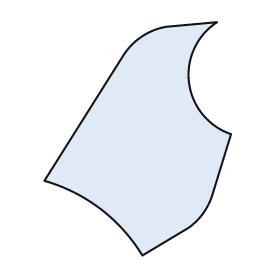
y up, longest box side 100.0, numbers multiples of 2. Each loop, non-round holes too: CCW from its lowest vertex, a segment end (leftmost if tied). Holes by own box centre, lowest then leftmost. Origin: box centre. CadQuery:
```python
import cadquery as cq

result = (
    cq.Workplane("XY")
    .moveTo(2.0, -50.0)
    .lineTo(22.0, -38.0)
    .threePointArc((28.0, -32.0), (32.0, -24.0))
    .lineTo(40.0, 2.0)
    .threePointArc((22.0, 24.0), (34.0, 50.0))
    .lineTo(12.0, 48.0)
    .threePointArc((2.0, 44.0), (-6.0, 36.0))
    .lineTo(-40.0, -18.0)
    .threePointArc((-16.0, -30.0), (2.0, -50.0))
    .close()
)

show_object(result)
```